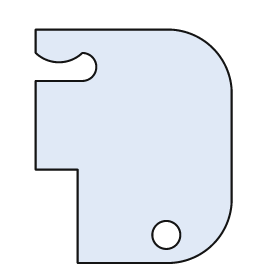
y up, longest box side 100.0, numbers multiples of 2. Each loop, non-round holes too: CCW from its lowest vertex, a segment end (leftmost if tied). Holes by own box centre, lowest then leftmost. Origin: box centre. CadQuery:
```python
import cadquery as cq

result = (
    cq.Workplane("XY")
    .moveTo(-24.0, -50.0)
    .lineTo(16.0, -50.0)
    .threePointArc((34.0, -42.0), (42.0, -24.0))
    .lineTo(42.0, 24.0)
    .threePointArc((34.0, 42.0), (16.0, 50.0))
    .lineTo(-42.0, 50.0)
    .lineTo(-42.0, 40.0)
    .threePointArc((-32.0, 36.0), (-22.0, 40.0))
    .threePointArc((-16.0, 34.0), (-22.0, 28.0))
    .lineTo(-42.0, 28.0)
    .lineTo(-42.0, -10.0)
    .lineTo(-24.0, -10.0)
    .close()
    .moveTo(14.0, -38.0)
    .circle(6.0)
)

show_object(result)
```